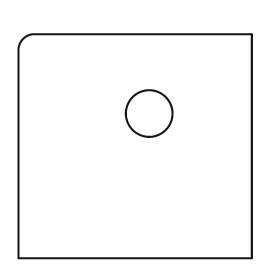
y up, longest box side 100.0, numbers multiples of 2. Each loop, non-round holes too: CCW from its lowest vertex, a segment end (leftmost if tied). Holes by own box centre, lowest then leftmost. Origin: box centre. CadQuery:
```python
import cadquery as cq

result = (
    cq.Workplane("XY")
    .moveTo(-50.0, -48.0)
    .lineTo(50.0, -48.0)
    .lineTo(50.0, 48.0)
    .lineTo(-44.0, 48.0)
    .threePointArc((-48.0, 46.0), (-50.0, 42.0))
    .close()
    .moveTo(6.0, 14.0)
    .circle(10.0)
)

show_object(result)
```